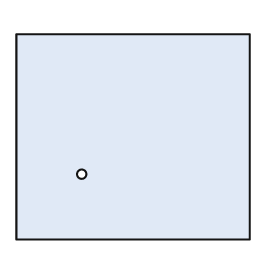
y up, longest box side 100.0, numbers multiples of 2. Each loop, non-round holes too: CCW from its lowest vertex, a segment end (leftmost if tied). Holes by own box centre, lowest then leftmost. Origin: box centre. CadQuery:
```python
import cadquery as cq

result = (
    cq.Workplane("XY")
    .moveTo(-50.0, -44.0)
    .lineTo(50.0, -44.0)
    .lineTo(50.0, 44.0)
    .lineTo(-50.0, 44.0)
    .close()
    .moveTo(-22.0, -16.0)
    .circle(2.0)
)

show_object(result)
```